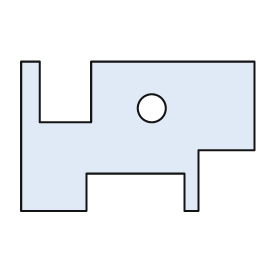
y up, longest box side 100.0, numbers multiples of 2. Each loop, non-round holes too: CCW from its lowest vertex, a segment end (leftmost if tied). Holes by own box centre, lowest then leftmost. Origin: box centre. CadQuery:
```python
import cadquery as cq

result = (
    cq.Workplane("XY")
    .moveTo(-50.0, -32.0)
    .lineTo(-22.0, -32.0)
    .lineTo(-22.0, -16.0)
    .lineTo(20.0, -16.0)
    .lineTo(20.0, -32.0)
    .lineTo(26.0, -32.0)
    .lineTo(26.0, -6.0)
    .lineTo(50.0, -6.0)
    .lineTo(50.0, 32.0)
    .lineTo(-20.0, 32.0)
    .lineTo(-20.0, 6.0)
    .lineTo(-42.0, 6.0)
    .lineTo(-42.0, 32.0)
    .lineTo(-50.0, 32.0)
    .close()
    .moveTo(6.0, 12.0)
    .circle(6.0)
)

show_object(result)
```